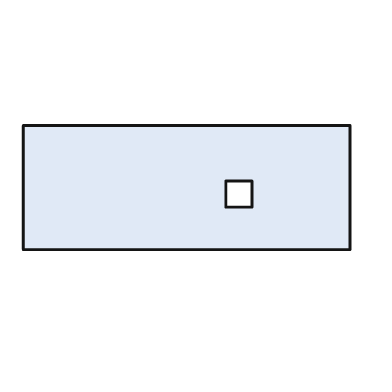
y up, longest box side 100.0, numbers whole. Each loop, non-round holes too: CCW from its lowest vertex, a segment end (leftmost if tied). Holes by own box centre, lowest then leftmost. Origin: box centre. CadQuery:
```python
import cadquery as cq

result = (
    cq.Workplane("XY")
    .moveTo(-50.0, -19.0)
    .lineTo(50.0, -19.0)
    .lineTo(50.0, 19.0)
    .lineTo(-50.0, 19.0)
    .close()
    .moveTo(12.0, -6.0)
    .lineTo(20.0, -6.0)
    .lineTo(20.0, 2.0)
    .lineTo(12.0, 2.0)
    .close()
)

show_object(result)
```